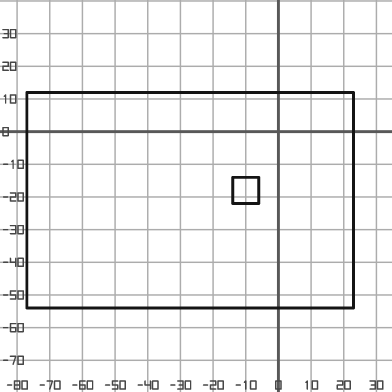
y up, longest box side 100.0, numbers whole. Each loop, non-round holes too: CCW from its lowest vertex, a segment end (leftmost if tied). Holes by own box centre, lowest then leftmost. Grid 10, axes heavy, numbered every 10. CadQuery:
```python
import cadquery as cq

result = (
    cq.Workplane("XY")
    .moveTo(-77.0, -54.0)
    .lineTo(23.0, -54.0)
    .lineTo(23.0, 12.0)
    .lineTo(-77.0, 12.0)
    .close()
    .moveTo(-14.0, -22.0)
    .lineTo(-6.0, -22.0)
    .lineTo(-6.0, -14.0)
    .lineTo(-14.0, -14.0)
    .close()
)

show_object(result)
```